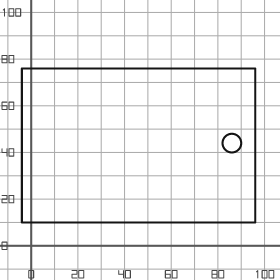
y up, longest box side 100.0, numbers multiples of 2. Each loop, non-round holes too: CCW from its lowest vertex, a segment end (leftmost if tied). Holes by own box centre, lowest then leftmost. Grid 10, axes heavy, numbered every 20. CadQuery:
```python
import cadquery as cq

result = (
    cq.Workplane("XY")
    .moveTo(-4.0, 10.0)
    .lineTo(96.0, 10.0)
    .lineTo(96.0, 76.0)
    .lineTo(-4.0, 76.0)
    .close()
    .moveTo(86.0, 44.0)
    .circle(4.0)
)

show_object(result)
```